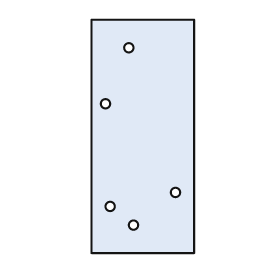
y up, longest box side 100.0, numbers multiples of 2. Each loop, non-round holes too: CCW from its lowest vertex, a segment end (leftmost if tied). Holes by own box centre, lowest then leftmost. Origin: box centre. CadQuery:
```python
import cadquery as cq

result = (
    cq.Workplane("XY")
    .moveTo(-22.0, -50.0)
    .lineTo(22.0, -50.0)
    .lineTo(22.0, 50.0)
    .lineTo(-22.0, 50.0)
    .close()
    .moveTo(-4.0, -38.0)
    .circle(2.0)
    .moveTo(-14.0, -30.0)
    .circle(2.0)
    .moveTo(14.0, -24.0)
    .circle(2.0)
    .moveTo(-16.0, 14.0)
    .circle(2.0)
    .moveTo(-6.0, 38.0)
    .circle(2.0)
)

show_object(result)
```